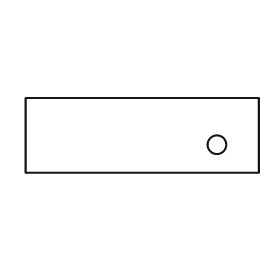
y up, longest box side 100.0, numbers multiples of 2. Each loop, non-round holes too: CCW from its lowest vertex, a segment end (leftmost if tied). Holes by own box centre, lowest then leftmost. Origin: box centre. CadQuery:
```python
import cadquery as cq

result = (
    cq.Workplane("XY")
    .moveTo(-50.0, -16.0)
    .lineTo(50.0, -16.0)
    .lineTo(50.0, 16.0)
    .lineTo(-50.0, 16.0)
    .close()
    .moveTo(32.0, -4.0)
    .circle(4.0)
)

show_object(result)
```